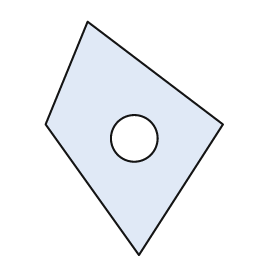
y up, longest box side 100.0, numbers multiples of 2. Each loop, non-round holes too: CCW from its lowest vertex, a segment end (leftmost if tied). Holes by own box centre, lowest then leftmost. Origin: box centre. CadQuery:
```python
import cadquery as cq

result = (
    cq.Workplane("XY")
    .moveTo(2.0, -50.0)
    .lineTo(38.0, 6.0)
    .lineTo(-20.0, 50.0)
    .lineTo(-38.0, 6.0)
    .close()
    .moveTo(0.0, 0.0)
    .circle(10.0)
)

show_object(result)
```